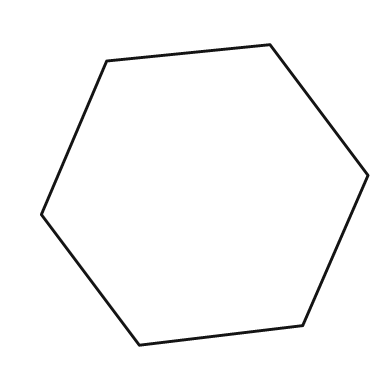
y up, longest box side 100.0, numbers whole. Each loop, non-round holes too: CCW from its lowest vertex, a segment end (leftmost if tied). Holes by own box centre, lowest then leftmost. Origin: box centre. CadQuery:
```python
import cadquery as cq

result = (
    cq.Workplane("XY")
    .moveTo(-20.0, -46.0)
    .lineTo(30.0, -40.0)
    .lineTo(50.0, 6.0)
    .lineTo(20.0, 46.0)
    .lineTo(-30.0, 41.0)
    .lineTo(-50.0, -6.0)
    .close()
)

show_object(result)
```